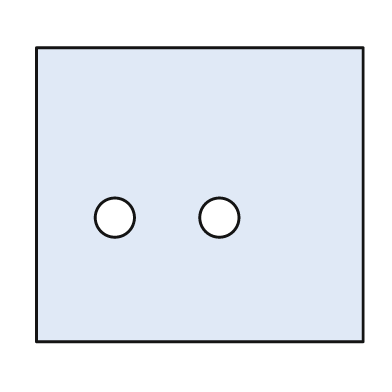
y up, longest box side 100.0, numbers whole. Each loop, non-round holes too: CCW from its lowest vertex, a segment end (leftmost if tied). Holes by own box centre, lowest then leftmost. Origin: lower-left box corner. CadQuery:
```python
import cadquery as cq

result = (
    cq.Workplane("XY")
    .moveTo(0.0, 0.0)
    .lineTo(100.0, 0.0)
    .lineTo(100.0, 90.0)
    .lineTo(0.0, 90.0)
    .close()
    .moveTo(24.0, 38.0)
    .circle(6.0)
    .moveTo(56.0, 38.0)
    .circle(6.0)
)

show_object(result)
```